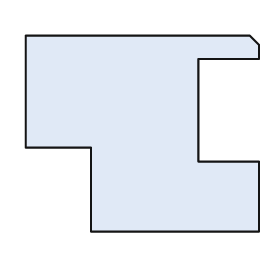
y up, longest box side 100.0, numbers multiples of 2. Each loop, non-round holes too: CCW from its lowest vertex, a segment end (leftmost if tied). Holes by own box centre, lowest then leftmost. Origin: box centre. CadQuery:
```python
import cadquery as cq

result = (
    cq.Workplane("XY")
    .moveTo(-22.0, -42.0)
    .lineTo(50.0, -42.0)
    .lineTo(50.0, -12.0)
    .lineTo(24.0, -12.0)
    .lineTo(24.0, 32.0)
    .lineTo(50.0, 32.0)
    .lineTo(50.0, 38.0)
    .lineTo(46.0, 42.0)
    .lineTo(-50.0, 42.0)
    .lineTo(-50.0, -6.0)
    .lineTo(-22.0, -6.0)
    .close()
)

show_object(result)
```